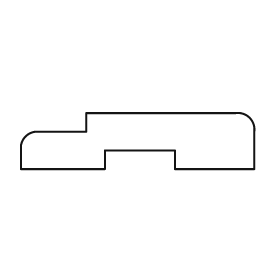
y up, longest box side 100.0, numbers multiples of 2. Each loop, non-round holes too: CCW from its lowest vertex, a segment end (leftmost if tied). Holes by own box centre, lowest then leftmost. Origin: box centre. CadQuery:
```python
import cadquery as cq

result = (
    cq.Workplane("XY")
    .moveTo(-50.0, -12.0)
    .lineTo(-14.0, -12.0)
    .lineTo(-14.0, -4.0)
    .lineTo(16.0, -4.0)
    .lineTo(16.0, -12.0)
    .lineTo(50.0, -12.0)
    .lineTo(50.0, 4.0)
    .threePointArc((48.0, 10.0), (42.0, 12.0))
    .lineTo(-22.0, 12.0)
    .lineTo(-22.0, 4.0)
    .lineTo(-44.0, 4.0)
    .threePointArc((-48.0, 2.0), (-50.0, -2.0))
    .close()
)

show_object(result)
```